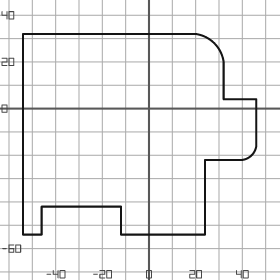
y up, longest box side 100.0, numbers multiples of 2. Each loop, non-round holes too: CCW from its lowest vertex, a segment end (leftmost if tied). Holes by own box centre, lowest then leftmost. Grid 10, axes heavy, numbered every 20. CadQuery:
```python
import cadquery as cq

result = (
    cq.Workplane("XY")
    .moveTo(-54.0, -54.0)
    .lineTo(-46.0, -54.0)
    .lineTo(-46.0, -42.0)
    .lineTo(-12.0, -42.0)
    .lineTo(-12.0, -54.0)
    .lineTo(24.0, -54.0)
    .lineTo(24.0, -22.0)
    .lineTo(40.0, -22.0)
    .threePointArc((44.0, -20.0), (46.0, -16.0))
    .lineTo(46.0, 4.0)
    .lineTo(32.0, 4.0)
    .lineTo(32.0, 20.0)
    .threePointArc((28.0, 28.0), (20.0, 32.0))
    .lineTo(-54.0, 32.0)
    .close()
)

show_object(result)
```